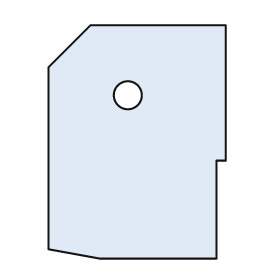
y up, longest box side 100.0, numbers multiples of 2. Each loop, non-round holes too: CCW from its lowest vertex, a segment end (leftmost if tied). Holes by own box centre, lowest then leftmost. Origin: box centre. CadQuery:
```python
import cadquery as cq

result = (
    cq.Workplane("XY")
    .moveTo(-16.0, -50.0)
    .lineTo(34.0, -50.0)
    .lineTo(34.0, -8.0)
    .lineTo(38.0, -8.0)
    .lineTo(38.0, 50.0)
    .lineTo(-20.0, 50.0)
    .lineTo(-38.0, 32.0)
    .lineTo(-38.0, -46.0)
    .close()
    .moveTo(-4.0, 20.0)
    .circle(6.0)
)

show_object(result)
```